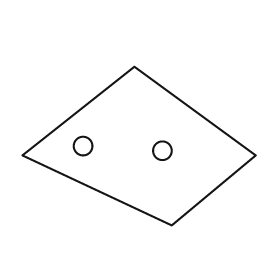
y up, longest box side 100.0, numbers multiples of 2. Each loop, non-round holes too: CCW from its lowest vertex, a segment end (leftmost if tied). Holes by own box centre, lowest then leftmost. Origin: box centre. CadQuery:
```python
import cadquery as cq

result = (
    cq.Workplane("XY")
    .moveTo(14.0, -34.0)
    .lineTo(50.0, -4.0)
    .lineTo(-2.0, 34.0)
    .lineTo(-50.0, -4.0)
    .close()
    .moveTo(10.0, -2.0)
    .circle(4.0)
    .moveTo(-24.0, 0.0)
    .circle(4.0)
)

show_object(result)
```